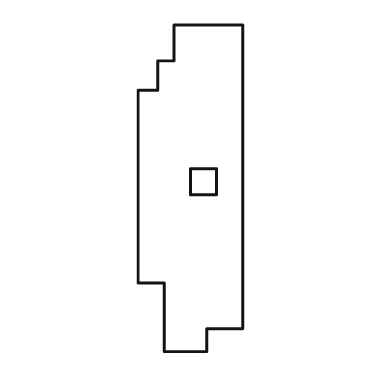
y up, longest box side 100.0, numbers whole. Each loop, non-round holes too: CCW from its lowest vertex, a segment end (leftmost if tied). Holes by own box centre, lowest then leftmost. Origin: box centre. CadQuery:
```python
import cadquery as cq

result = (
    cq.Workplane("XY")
    .moveTo(-8.0, -50.0)
    .lineTo(5.0, -50.0)
    .lineTo(5.0, -43.0)
    .lineTo(16.0, -43.0)
    .lineTo(16.0, 50.0)
    .lineTo(-5.0, 50.0)
    .lineTo(-5.0, 39.0)
    .lineTo(-10.0, 39.0)
    .lineTo(-10.0, 30.0)
    .lineTo(-16.0, 30.0)
    .lineTo(-16.0, -29.0)
    .lineTo(-8.0, -29.0)
    .close()
    .moveTo(0.0, -2.0)
    .lineTo(8.0, -2.0)
    .lineTo(8.0, 6.0)
    .lineTo(0.0, 6.0)
    .close()
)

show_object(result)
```